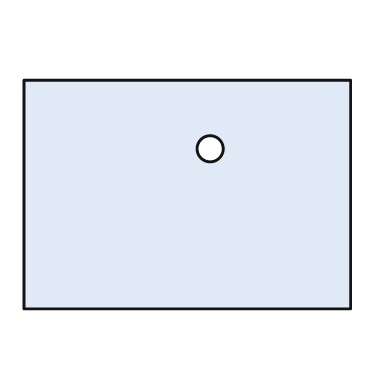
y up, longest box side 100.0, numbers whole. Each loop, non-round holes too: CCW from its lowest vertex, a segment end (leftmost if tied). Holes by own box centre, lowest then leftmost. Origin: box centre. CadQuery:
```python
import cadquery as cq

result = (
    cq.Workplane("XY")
    .moveTo(-50.0, -35.0)
    .lineTo(50.0, -35.0)
    .lineTo(50.0, 35.0)
    .lineTo(-50.0, 35.0)
    .close()
    .moveTo(7.0, 14.0)
    .circle(4.0)
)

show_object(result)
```